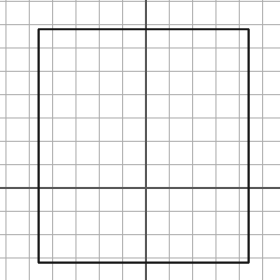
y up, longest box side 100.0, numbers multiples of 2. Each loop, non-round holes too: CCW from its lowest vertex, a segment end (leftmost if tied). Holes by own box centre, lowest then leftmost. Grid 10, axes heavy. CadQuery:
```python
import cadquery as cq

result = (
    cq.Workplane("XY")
    .moveTo(-46.0, -32.0)
    .lineTo(44.0, -32.0)
    .lineTo(44.0, 68.0)
    .lineTo(-46.0, 68.0)
    .close()
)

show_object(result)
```